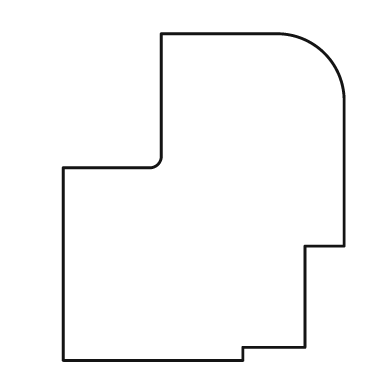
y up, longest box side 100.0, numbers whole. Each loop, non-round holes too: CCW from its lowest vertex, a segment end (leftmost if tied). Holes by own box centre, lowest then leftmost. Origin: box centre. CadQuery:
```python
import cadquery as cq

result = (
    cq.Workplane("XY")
    .moveTo(-43.0, -50.0)
    .lineTo(12.0, -50.0)
    .lineTo(12.0, -46.0)
    .lineTo(31.0, -46.0)
    .lineTo(31.0, -15.0)
    .lineTo(43.0, -15.0)
    .lineTo(43.0, 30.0)
    .threePointArc((37.0, 44.0), (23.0, 50.0))
    .lineTo(-13.0, 50.0)
    .lineTo(-13.0, 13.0)
    .threePointArc((-14.0, 10.0), (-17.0, 9.0))
    .lineTo(-43.0, 9.0)
    .close()
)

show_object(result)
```